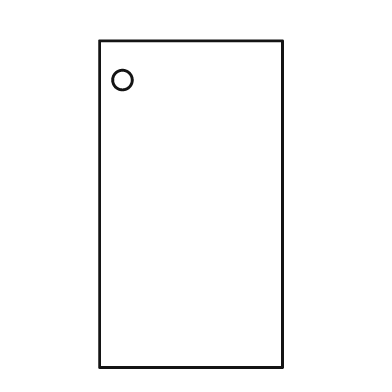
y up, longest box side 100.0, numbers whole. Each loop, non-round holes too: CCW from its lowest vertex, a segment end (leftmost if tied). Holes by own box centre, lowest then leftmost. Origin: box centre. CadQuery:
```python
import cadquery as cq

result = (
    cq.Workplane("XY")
    .moveTo(-28.0, -50.0)
    .lineTo(28.0, -50.0)
    .lineTo(28.0, 50.0)
    .lineTo(-28.0, 50.0)
    .close()
    .moveTo(-21.0, 38.0)
    .circle(3.0)
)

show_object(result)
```